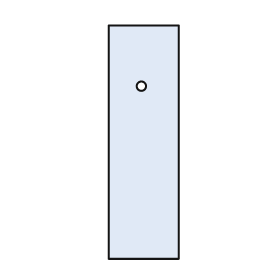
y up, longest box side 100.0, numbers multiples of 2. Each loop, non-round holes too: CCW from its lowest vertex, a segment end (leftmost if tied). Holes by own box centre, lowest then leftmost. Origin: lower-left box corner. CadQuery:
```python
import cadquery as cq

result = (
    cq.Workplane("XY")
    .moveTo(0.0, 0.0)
    .lineTo(30.0, 0.0)
    .lineTo(30.0, 100.0)
    .lineTo(0.0, 100.0)
    .close()
    .moveTo(14.0, 74.0)
    .circle(2.0)
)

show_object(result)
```